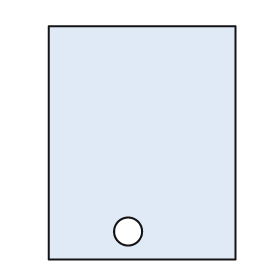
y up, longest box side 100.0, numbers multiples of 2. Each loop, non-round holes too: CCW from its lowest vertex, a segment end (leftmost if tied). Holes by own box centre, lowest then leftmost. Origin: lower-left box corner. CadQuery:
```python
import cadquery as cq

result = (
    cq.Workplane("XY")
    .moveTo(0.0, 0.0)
    .lineTo(80.0, 0.0)
    .lineTo(80.0, 100.0)
    .lineTo(0.0, 100.0)
    .close()
    .moveTo(34.0, 12.0)
    .circle(6.0)
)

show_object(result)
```